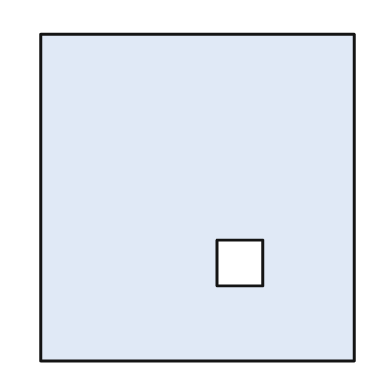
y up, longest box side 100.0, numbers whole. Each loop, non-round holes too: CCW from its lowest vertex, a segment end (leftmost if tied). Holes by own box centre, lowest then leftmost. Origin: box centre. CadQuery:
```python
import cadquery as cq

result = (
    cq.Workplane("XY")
    .moveTo(-48.0, -50.0)
    .lineTo(48.0, -50.0)
    .lineTo(48.0, 50.0)
    .lineTo(-48.0, 50.0)
    .close()
    .moveTo(6.0, -27.0)
    .lineTo(20.0, -27.0)
    .lineTo(20.0, -13.0)
    .lineTo(6.0, -13.0)
    .close()
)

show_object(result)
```